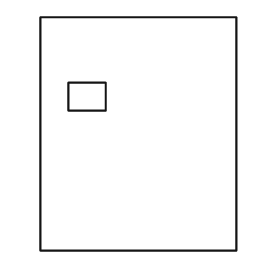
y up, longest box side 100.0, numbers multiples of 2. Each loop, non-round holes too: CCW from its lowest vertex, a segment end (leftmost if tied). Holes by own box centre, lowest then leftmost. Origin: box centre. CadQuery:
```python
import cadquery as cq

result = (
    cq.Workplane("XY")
    .moveTo(-42.0, -50.0)
    .lineTo(42.0, -50.0)
    .lineTo(42.0, 50.0)
    .lineTo(-42.0, 50.0)
    .close()
    .moveTo(-30.0, 10.0)
    .lineTo(-14.0, 10.0)
    .lineTo(-14.0, 22.0)
    .lineTo(-30.0, 22.0)
    .close()
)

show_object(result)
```